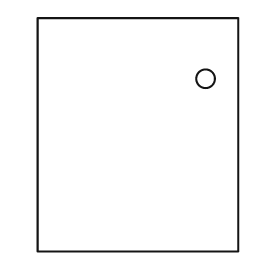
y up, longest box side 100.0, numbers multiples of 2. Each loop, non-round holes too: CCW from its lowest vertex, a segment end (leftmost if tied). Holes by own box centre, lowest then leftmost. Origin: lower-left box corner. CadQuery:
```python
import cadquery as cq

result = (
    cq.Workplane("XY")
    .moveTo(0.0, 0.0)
    .lineTo(86.0, 0.0)
    .lineTo(86.0, 100.0)
    .lineTo(0.0, 100.0)
    .close()
    .moveTo(72.0, 74.0)
    .circle(4.0)
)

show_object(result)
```